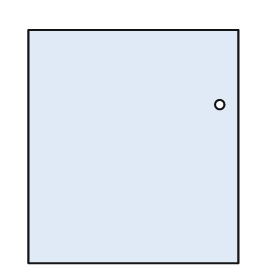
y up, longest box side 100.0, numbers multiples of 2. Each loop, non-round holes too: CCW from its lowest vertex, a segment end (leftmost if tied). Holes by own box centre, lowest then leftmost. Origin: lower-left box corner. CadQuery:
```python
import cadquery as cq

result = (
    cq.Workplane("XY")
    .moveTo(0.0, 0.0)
    .lineTo(90.0, 0.0)
    .lineTo(90.0, 100.0)
    .lineTo(0.0, 100.0)
    .close()
    .moveTo(82.0, 68.0)
    .circle(2.0)
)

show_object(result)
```